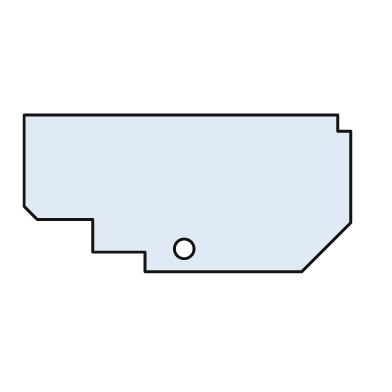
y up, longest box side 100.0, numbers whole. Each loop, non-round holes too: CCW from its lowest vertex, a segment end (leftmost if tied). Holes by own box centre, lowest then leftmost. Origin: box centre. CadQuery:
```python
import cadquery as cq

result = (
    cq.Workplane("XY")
    .moveTo(-13.0, -24.0)
    .lineTo(35.0, -24.0)
    .lineTo(50.0, -9.0)
    .lineTo(50.0, 19.0)
    .lineTo(46.0, 19.0)
    .lineTo(46.0, 24.0)
    .lineTo(-50.0, 24.0)
    .lineTo(-50.0, -4.0)
    .lineTo(-46.0, -8.0)
    .lineTo(-29.0, -8.0)
    .lineTo(-29.0, -18.0)
    .lineTo(-13.0, -18.0)
    .close()
    .moveTo(-1.0, -17.0)
    .circle(3.0)
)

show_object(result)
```